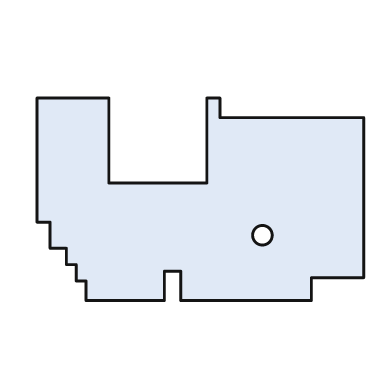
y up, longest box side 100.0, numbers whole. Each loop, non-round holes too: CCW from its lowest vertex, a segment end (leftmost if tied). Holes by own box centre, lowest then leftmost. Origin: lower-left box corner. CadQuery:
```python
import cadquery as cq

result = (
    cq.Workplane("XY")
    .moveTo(15.0, 0.0)
    .lineTo(39.0, 0.0)
    .lineTo(39.0, 9.0)
    .lineTo(44.0, 9.0)
    .lineTo(44.0, 0.0)
    .lineTo(84.0, 0.0)
    .lineTo(84.0, 7.0)
    .lineTo(100.0, 7.0)
    .lineTo(100.0, 56.0)
    .lineTo(56.0, 56.0)
    .lineTo(56.0, 62.0)
    .lineTo(52.0, 62.0)
    .lineTo(52.0, 36.0)
    .lineTo(22.0, 36.0)
    .lineTo(22.0, 62.0)
    .lineTo(0.0, 62.0)
    .lineTo(0.0, 24.0)
    .lineTo(4.0, 24.0)
    .lineTo(4.0, 16.0)
    .lineTo(9.0, 16.0)
    .lineTo(9.0, 11.0)
    .lineTo(12.0, 11.0)
    .lineTo(12.0, 6.0)
    .lineTo(15.0, 6.0)
    .close()
    .moveTo(69.0, 20.0)
    .circle(3.0)
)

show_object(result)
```